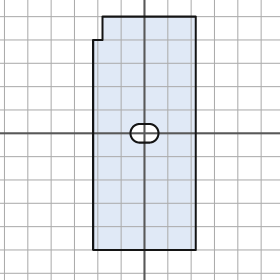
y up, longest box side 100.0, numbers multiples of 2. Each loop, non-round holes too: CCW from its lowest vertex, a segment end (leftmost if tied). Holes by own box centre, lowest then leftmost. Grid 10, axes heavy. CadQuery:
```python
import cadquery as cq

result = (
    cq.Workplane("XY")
    .moveTo(-22.0, -50.0)
    .lineTo(22.0, -50.0)
    .lineTo(22.0, 50.0)
    .lineTo(-18.0, 50.0)
    .lineTo(-18.0, 40.0)
    .lineTo(-22.0, 40.0)
    .close()
    .moveTo(-2.0, -4.0)
    .lineTo(2.0, -4.0)
    .threePointArc((6.0, 0.0), (2.0, 4.0))
    .lineTo(-2.0, 4.0)
    .threePointArc((-6.0, 0.0), (-2.0, -4.0))
    .close()
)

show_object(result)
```